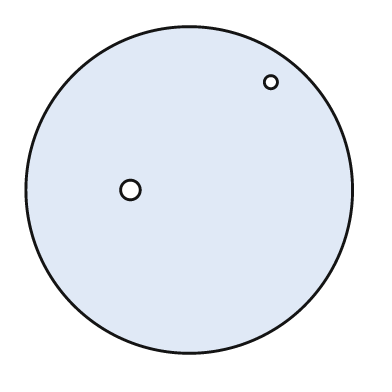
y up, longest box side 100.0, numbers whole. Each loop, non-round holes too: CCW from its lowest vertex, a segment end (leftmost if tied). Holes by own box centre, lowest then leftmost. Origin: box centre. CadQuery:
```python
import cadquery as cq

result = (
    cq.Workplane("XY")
    .moveTo(0.0, 0.0)
    .circle(50.0)
    .moveTo(-18.0, 0.0)
    .circle(3.0)
    .moveTo(25.0, 33.0)
    .circle(2.0)
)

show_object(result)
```